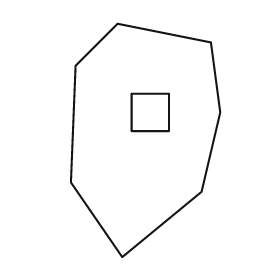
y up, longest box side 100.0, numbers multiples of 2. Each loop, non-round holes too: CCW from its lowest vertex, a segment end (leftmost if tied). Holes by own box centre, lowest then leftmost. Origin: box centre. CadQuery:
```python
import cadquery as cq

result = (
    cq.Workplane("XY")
    .moveTo(-10.0, -50.0)
    .lineTo(24.0, -22.0)
    .lineTo(32.0, 12.0)
    .lineTo(28.0, 42.0)
    .lineTo(-12.0, 50.0)
    .lineTo(-30.0, 32.0)
    .lineTo(-32.0, -18.0)
    .close()
    .moveTo(-6.0, 4.0)
    .lineTo(10.0, 4.0)
    .lineTo(10.0, 20.0)
    .lineTo(-6.0, 20.0)
    .close()
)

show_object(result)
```